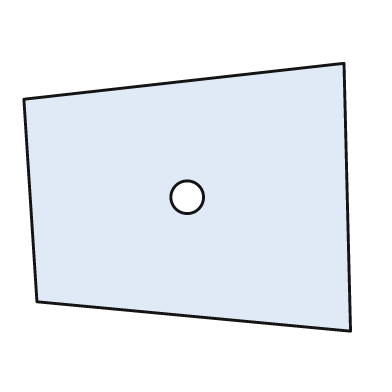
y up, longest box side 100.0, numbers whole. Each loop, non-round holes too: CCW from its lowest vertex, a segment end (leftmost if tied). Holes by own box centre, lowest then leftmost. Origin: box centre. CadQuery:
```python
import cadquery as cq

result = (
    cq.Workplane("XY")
    .moveTo(50.0, -41.0)
    .lineTo(48.0, 41.0)
    .lineTo(-50.0, 30.0)
    .lineTo(-46.0, -32.0)
    .close()
    .moveTo(0.0, 0.0)
    .circle(5.0)
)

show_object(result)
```